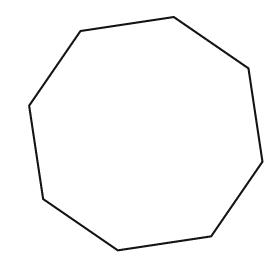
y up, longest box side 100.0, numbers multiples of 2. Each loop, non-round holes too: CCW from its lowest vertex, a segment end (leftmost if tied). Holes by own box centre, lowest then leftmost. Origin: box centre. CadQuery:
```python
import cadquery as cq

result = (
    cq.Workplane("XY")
    .moveTo(-12.0, -50.0)
    .lineTo(28.0, -44.0)
    .lineTo(50.0, -12.0)
    .lineTo(44.0, 28.0)
    .lineTo(12.0, 50.0)
    .lineTo(-28.0, 44.0)
    .lineTo(-50.0, 12.0)
    .lineTo(-44.0, -28.0)
    .close()
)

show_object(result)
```